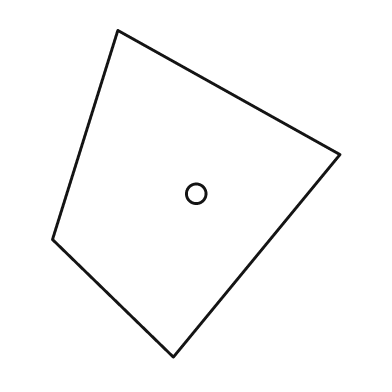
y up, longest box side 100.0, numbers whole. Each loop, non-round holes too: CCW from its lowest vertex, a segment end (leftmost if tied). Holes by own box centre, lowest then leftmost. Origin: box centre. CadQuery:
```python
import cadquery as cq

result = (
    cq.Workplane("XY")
    .moveTo(-7.0, -50.0)
    .lineTo(44.0, 12.0)
    .lineTo(-24.0, 50.0)
    .lineTo(-44.0, -14.0)
    .close()
    .moveTo(0.0, 0.0)
    .circle(3.0)
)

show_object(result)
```